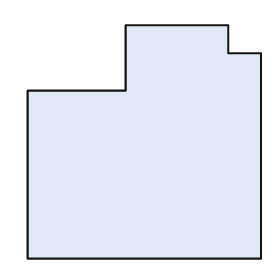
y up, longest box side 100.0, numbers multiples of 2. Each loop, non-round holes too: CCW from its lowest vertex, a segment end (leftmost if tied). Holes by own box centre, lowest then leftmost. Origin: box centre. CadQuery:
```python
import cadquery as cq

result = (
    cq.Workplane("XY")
    .moveTo(-50.0, -50.0)
    .lineTo(50.0, -50.0)
    .lineTo(50.0, 38.0)
    .lineTo(36.0, 38.0)
    .lineTo(36.0, 50.0)
    .lineTo(-8.0, 50.0)
    .lineTo(-8.0, 22.0)
    .lineTo(-50.0, 22.0)
    .close()
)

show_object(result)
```